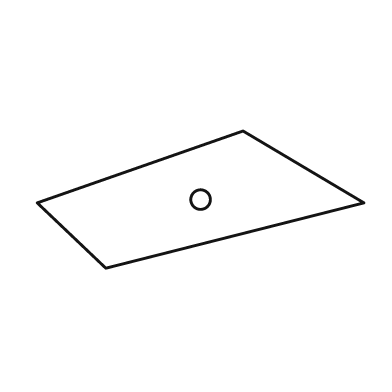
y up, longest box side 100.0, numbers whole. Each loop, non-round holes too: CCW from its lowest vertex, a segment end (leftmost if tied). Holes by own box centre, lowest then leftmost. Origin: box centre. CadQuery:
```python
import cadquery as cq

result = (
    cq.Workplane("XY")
    .moveTo(-29.0, -21.0)
    .lineTo(50.0, -1.0)
    .lineTo(13.0, 21.0)
    .lineTo(-50.0, -1.0)
    .close()
    .moveTo(0.0, 0.0)
    .circle(3.0)
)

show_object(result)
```